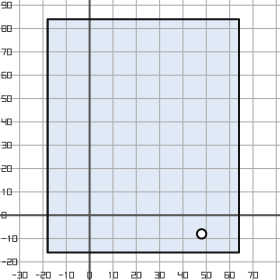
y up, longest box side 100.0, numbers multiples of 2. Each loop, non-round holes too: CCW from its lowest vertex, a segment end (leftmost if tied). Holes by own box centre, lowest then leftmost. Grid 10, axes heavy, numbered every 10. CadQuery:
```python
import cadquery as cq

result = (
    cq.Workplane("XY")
    .moveTo(-18.0, -16.0)
    .lineTo(64.0, -16.0)
    .lineTo(64.0, 84.0)
    .lineTo(-18.0, 84.0)
    .close()
    .moveTo(48.0, -8.0)
    .circle(2.0)
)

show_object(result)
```